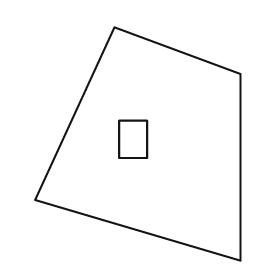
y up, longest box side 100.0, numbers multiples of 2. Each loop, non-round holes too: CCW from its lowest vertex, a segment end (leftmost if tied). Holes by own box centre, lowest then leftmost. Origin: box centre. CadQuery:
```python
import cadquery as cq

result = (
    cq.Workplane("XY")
    .moveTo(44.0, -50.0)
    .lineTo(44.0, 30.0)
    .lineTo(-10.0, 50.0)
    .lineTo(-44.0, -24.0)
    .close()
    .moveTo(-8.0, -6.0)
    .lineTo(4.0, -6.0)
    .lineTo(4.0, 10.0)
    .lineTo(-8.0, 10.0)
    .close()
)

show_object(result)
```